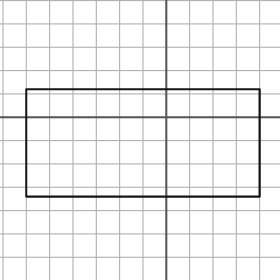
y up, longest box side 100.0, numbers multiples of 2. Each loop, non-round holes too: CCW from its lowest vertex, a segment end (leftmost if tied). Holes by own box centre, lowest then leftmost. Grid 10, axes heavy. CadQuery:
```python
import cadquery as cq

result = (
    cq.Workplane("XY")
    .moveTo(-60.0, -34.0)
    .lineTo(40.0, -34.0)
    .lineTo(40.0, 12.0)
    .lineTo(-60.0, 12.0)
    .close()
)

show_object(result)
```